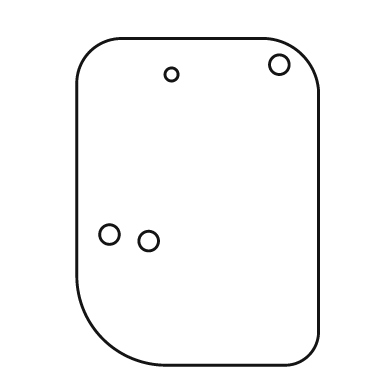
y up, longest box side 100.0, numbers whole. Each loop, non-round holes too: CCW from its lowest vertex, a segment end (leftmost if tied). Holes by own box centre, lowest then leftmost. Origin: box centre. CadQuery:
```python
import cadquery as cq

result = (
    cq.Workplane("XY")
    .moveTo(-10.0, -50.0)
    .lineTo(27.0, -50.0)
    .threePointArc((34.0, -47.0), (37.0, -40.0))
    .lineTo(37.0, 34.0)
    .threePointArc((32.0, 45.0), (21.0, 50.0))
    .lineTo(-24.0, 50.0)
    .threePointArc((-33.0, 46.0), (-37.0, 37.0))
    .lineTo(-37.0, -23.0)
    .threePointArc((-29.0, -42.0), (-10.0, -50.0))
    .close()
    .moveTo(-15.0, -12.0)
    .circle(3.0)
    .moveTo(-27.0, -10.0)
    .circle(3.0)
    .moveTo(-8.0, 39.0)
    .circle(2.0)
    .moveTo(25.0, 42.0)
    .circle(3.0)
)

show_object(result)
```